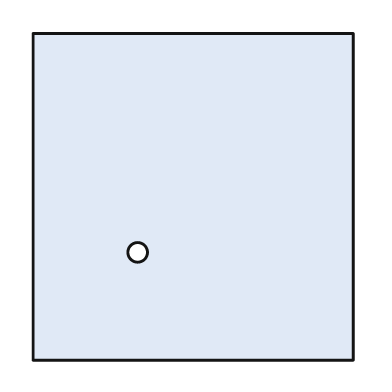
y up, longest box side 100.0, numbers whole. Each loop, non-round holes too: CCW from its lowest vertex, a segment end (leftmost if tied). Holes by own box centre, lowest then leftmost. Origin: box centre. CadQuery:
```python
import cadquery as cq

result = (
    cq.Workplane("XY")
    .moveTo(-49.0, -50.0)
    .lineTo(49.0, -50.0)
    .lineTo(49.0, 50.0)
    .lineTo(-49.0, 50.0)
    .close()
    .moveTo(-17.0, -17.0)
    .circle(3.0)
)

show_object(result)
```